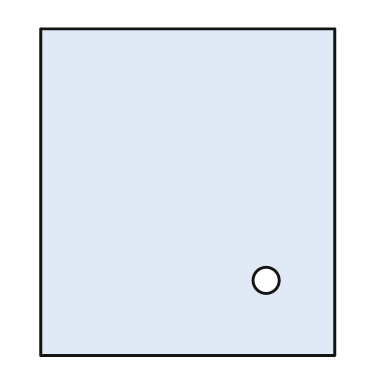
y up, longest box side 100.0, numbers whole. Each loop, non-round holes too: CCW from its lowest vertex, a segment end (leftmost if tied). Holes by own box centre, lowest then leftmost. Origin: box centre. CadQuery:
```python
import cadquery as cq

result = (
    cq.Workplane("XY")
    .moveTo(-45.0, -50.0)
    .lineTo(45.0, -50.0)
    .lineTo(45.0, 50.0)
    .lineTo(-45.0, 50.0)
    .close()
    .moveTo(24.0, -27.0)
    .circle(4.0)
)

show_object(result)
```